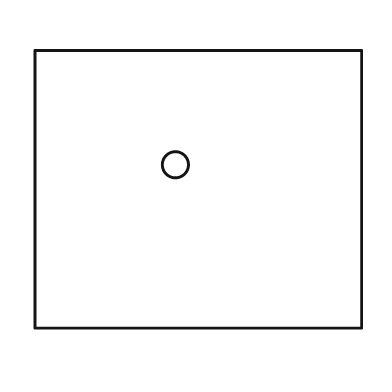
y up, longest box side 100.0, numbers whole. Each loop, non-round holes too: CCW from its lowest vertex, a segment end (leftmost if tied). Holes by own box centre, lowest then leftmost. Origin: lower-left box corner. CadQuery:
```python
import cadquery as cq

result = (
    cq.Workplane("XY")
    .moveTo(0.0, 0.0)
    .lineTo(100.0, 0.0)
    .lineTo(100.0, 85.0)
    .lineTo(0.0, 85.0)
    .close()
    .moveTo(43.0, 50.0)
    .circle(4.0)
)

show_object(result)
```